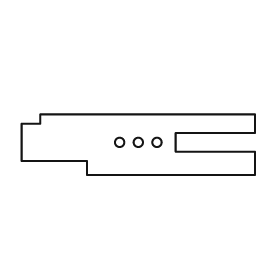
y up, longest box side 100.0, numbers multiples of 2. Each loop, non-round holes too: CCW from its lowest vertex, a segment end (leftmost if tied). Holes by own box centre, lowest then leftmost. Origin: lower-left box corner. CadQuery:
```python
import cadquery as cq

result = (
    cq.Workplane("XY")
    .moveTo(28.0, 0.0)
    .lineTo(100.0, 0.0)
    .lineTo(100.0, 10.0)
    .lineTo(66.0, 10.0)
    .lineTo(66.0, 18.0)
    .lineTo(100.0, 18.0)
    .lineTo(100.0, 26.0)
    .lineTo(8.0, 26.0)
    .lineTo(8.0, 22.0)
    .lineTo(0.0, 22.0)
    .lineTo(0.0, 6.0)
    .lineTo(28.0, 6.0)
    .close()
    .moveTo(42.0, 14.0)
    .circle(2.0)
    .moveTo(50.0, 14.0)
    .circle(2.0)
    .moveTo(58.0, 14.0)
    .circle(2.0)
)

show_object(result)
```